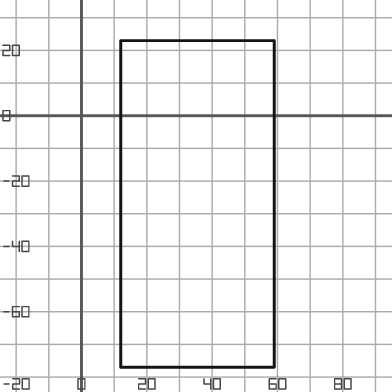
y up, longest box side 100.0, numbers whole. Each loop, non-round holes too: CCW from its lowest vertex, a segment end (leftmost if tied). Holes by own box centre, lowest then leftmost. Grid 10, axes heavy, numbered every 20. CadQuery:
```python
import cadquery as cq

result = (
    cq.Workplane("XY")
    .moveTo(12.0, -77.0)
    .lineTo(59.0, -77.0)
    .lineTo(59.0, 23.0)
    .lineTo(12.0, 23.0)
    .close()
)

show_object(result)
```